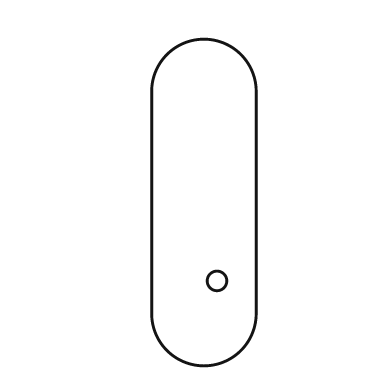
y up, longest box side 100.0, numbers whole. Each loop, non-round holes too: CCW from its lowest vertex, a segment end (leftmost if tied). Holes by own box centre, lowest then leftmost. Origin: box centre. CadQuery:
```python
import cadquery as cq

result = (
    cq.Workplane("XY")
    .moveTo(-16.0, -34.0)
    .threePointArc((0.0, -50.0), (16.0, -34.0))
    .lineTo(16.0, 34.0)
    .threePointArc((0.0, 50.0), (-16.0, 34.0))
    .close()
    .moveTo(4.0, -24.0)
    .circle(3.0)
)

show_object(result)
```